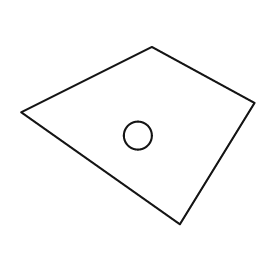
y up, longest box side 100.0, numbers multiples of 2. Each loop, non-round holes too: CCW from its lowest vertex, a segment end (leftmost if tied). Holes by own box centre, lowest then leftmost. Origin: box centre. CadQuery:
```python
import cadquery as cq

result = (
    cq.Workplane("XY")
    .moveTo(18.0, -38.0)
    .lineTo(50.0, 14.0)
    .lineTo(6.0, 38.0)
    .lineTo(-50.0, 10.0)
    .close()
    .moveTo(0.0, 0.0)
    .circle(6.0)
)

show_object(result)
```